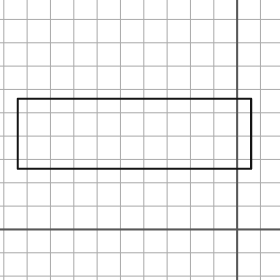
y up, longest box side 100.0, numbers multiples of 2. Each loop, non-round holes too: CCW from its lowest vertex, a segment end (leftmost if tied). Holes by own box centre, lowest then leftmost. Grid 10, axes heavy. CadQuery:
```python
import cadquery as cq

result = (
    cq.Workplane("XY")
    .moveTo(-94.0, 26.0)
    .lineTo(6.0, 26.0)
    .lineTo(6.0, 56.0)
    .lineTo(-94.0, 56.0)
    .close()
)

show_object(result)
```